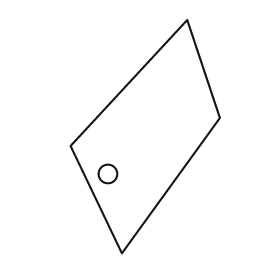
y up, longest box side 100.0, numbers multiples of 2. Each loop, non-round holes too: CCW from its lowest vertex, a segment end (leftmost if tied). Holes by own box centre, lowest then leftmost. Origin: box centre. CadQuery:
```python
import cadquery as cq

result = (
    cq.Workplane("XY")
    .moveTo(-10.0, -50.0)
    .lineTo(32.0, 8.0)
    .lineTo(18.0, 50.0)
    .lineTo(-32.0, -4.0)
    .close()
    .moveTo(-16.0, -16.0)
    .circle(4.0)
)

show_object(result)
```